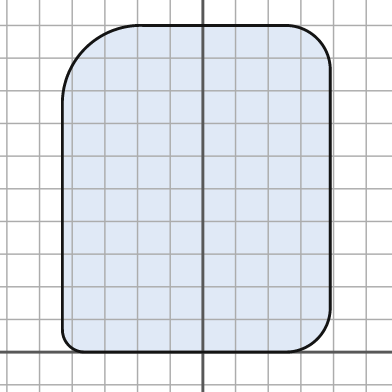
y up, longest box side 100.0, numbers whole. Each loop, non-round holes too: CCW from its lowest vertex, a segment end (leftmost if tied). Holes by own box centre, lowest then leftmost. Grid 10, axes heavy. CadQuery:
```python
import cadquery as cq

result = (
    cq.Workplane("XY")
    .moveTo(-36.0, 0.0)
    .lineTo(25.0, 0.0)
    .threePointArc((35.0, 4.0), (39.0, 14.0))
    .lineTo(39.0, 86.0)
    .threePointArc((35.0, 96.0), (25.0, 100.0))
    .lineTo(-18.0, 100.0)
    .threePointArc((-36.0, 93.0), (-43.0, 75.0))
    .lineTo(-43.0, 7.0)
    .threePointArc((-41.0, 2.0), (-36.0, 0.0))
    .close()
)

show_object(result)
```